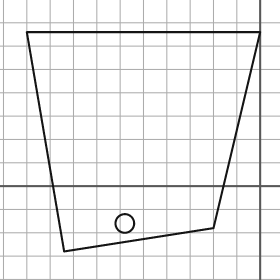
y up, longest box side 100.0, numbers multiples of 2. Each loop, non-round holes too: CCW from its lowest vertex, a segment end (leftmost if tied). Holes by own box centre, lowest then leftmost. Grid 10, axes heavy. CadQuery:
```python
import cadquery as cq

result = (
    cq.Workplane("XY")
    .moveTo(-84.0, -28.0)
    .lineTo(-20.0, -18.0)
    .lineTo(0.0, 66.0)
    .lineTo(-100.0, 66.0)
    .close()
    .moveTo(-58.0, -16.0)
    .circle(4.0)
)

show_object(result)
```